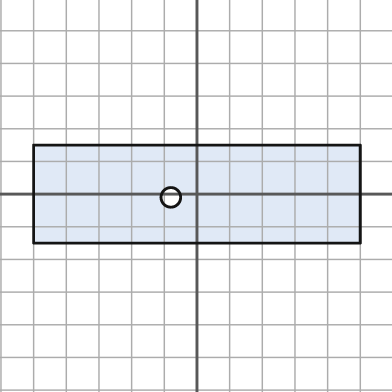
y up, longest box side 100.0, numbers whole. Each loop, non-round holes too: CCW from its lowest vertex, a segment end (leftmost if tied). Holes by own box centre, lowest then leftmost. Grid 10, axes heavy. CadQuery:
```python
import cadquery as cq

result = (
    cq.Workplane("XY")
    .moveTo(-50.0, -15.0)
    .lineTo(50.0, -15.0)
    .lineTo(50.0, 15.0)
    .lineTo(-50.0, 15.0)
    .close()
    .moveTo(-8.0, -1.0)
    .circle(3.0)
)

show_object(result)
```